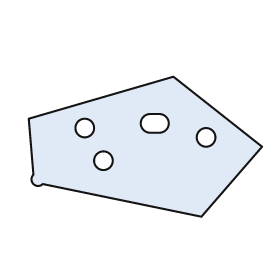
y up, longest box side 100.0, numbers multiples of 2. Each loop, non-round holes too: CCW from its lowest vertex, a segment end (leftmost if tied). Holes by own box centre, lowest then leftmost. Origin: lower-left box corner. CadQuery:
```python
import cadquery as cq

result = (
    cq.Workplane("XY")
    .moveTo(74.0, 0.0)
    .lineTo(100.0, 30.0)
    .lineTo(62.0, 60.0)
    .lineTo(0.0, 42.0)
    .lineTo(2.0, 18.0)
    .threePointArc((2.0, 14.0), (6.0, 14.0))
    .close()
    .moveTo(32.0, 24.0)
    .circle(4.0)
    .moveTo(76.0, 34.0)
    .circle(4.0)
    .moveTo(24.0, 38.0)
    .circle(4.0)
    .moveTo(52.0, 36.0)
    .lineTo(56.0, 36.0)
    .threePointArc((60.0, 40.0), (56.0, 44.0))
    .lineTo(52.0, 44.0)
    .threePointArc((48.0, 40.0), (52.0, 36.0))
    .close()
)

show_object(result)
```